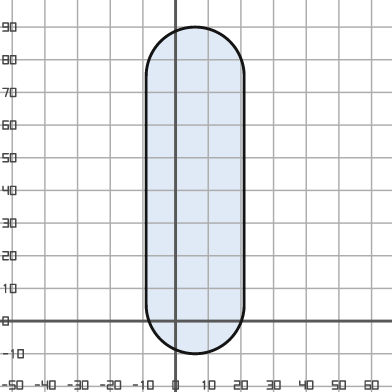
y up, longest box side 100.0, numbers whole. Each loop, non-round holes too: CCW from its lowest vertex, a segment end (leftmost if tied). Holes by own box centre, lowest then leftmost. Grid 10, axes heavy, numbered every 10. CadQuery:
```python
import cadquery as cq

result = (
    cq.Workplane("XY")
    .moveTo(-9.0, 5.0)
    .threePointArc((6.0, -10.0), (21.0, 5.0))
    .lineTo(21.0, 75.0)
    .threePointArc((6.0, 90.0), (-9.0, 75.0))
    .close()
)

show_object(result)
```